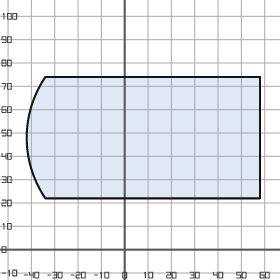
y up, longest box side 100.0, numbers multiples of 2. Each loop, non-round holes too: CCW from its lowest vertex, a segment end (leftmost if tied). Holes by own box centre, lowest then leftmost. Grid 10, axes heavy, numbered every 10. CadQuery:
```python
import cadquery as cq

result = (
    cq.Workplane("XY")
    .moveTo(-34.0, 22.0)
    .lineTo(58.0, 22.0)
    .lineTo(58.0, 74.0)
    .lineTo(-34.0, 74.0)
    .threePointArc((-42.0, 48.0), (-34.0, 22.0))
    .close()
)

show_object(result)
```